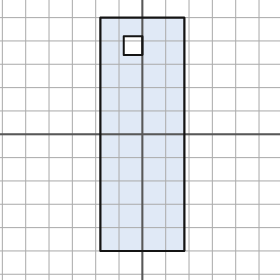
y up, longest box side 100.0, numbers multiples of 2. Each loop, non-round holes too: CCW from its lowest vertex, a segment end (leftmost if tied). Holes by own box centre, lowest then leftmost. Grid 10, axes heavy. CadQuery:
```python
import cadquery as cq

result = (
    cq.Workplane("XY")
    .moveTo(-18.0, -50.0)
    .lineTo(18.0, -50.0)
    .lineTo(18.0, 50.0)
    .lineTo(-18.0, 50.0)
    .close()
    .moveTo(-8.0, 34.0)
    .lineTo(0.0, 34.0)
    .lineTo(0.0, 42.0)
    .lineTo(-8.0, 42.0)
    .close()
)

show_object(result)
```